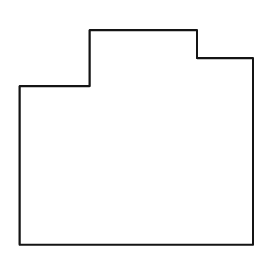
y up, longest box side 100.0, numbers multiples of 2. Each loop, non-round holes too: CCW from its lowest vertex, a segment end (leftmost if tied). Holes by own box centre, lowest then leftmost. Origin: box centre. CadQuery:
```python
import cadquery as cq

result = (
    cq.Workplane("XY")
    .moveTo(-50.0, -46.0)
    .lineTo(50.0, -46.0)
    .lineTo(50.0, 34.0)
    .lineTo(26.0, 34.0)
    .lineTo(26.0, 46.0)
    .lineTo(-20.0, 46.0)
    .lineTo(-20.0, 22.0)
    .lineTo(-50.0, 22.0)
    .close()
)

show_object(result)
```